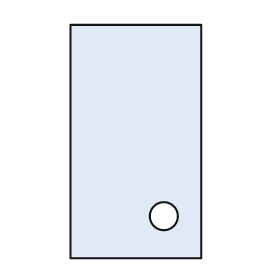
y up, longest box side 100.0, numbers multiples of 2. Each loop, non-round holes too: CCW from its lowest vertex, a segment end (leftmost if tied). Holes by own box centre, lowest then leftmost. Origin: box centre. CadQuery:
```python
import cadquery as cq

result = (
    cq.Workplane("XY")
    .moveTo(-28.0, -50.0)
    .lineTo(28.0, -50.0)
    .lineTo(28.0, 50.0)
    .lineTo(-28.0, 50.0)
    .close()
    .moveTo(12.0, -32.0)
    .circle(6.0)
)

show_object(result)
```